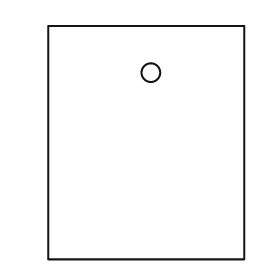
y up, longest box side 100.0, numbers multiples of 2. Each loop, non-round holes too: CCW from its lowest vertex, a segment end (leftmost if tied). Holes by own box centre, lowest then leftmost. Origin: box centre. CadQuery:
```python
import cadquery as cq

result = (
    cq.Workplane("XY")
    .moveTo(-42.0, -50.0)
    .lineTo(42.0, -50.0)
    .lineTo(42.0, 50.0)
    .lineTo(-42.0, 50.0)
    .close()
    .moveTo(2.0, 30.0)
    .circle(4.0)
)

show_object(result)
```